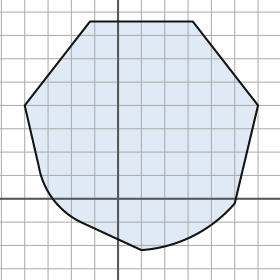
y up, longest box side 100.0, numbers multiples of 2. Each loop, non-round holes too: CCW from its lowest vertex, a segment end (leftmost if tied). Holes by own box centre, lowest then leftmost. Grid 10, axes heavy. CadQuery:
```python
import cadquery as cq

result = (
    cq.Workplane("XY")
    .moveTo(10.0, -22.0)
    .threePointArc((32.0, -16.0), (50.0, -2.0))
    .lineTo(60.0, 40.0)
    .lineTo(32.0, 76.0)
    .lineTo(-12.0, 76.0)
    .lineTo(-40.0, 40.0)
    .lineTo(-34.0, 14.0)
    .threePointArc((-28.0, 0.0), (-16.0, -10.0))
    .close()
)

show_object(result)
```